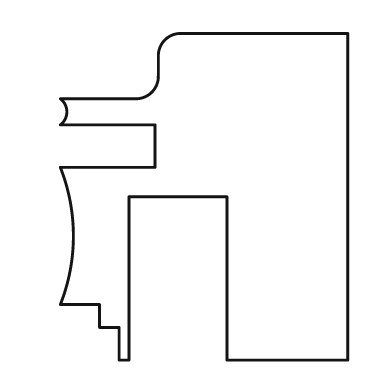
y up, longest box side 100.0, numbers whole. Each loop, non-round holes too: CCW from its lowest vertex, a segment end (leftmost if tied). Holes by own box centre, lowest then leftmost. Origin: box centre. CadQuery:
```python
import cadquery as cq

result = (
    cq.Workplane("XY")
    .moveTo(-26.0, -50.0)
    .lineTo(-23.0, -50.0)
    .lineTo(-23.0, 0.0)
    .lineTo(7.0, 0.0)
    .lineTo(7.0, -50.0)
    .lineTo(44.0, -50.0)
    .lineTo(44.0, 50.0)
    .lineTo(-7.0, 50.0)
    .threePointArc((-12.0, 48.0), (-14.0, 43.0))
    .lineTo(-14.0, 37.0)
    .threePointArc((-16.0, 32.0), (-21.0, 30.0))
    .lineTo(-44.0, 30.0)
    .threePointArc((-42.0, 26.0), (-44.0, 22.0))
    .lineTo(-15.0, 22.0)
    .lineTo(-15.0, 9.0)
    .lineTo(-44.0, 9.0)
    .threePointArc((-40.0, -12.0), (-44.0, -33.0))
    .lineTo(-32.0, -33.0)
    .lineTo(-32.0, -40.0)
    .lineTo(-26.0, -40.0)
    .close()
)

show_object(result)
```